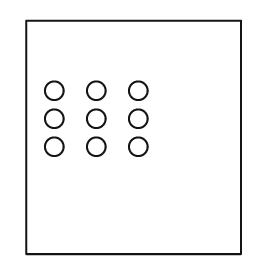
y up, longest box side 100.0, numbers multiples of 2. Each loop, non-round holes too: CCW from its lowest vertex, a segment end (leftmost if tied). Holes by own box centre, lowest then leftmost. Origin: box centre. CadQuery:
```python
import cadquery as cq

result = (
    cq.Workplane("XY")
    .moveTo(-46.0, -50.0)
    .lineTo(46.0, -50.0)
    .lineTo(46.0, 50.0)
    .lineTo(-46.0, 50.0)
    .close()
    .moveTo(-34.0, -4.0)
    .circle(4.0)
    .moveTo(-16.0, -4.0)
    .circle(4.0)
    .moveTo(2.0, -4.0)
    .circle(4.0)
    .moveTo(-34.0, 8.0)
    .circle(4.0)
    .moveTo(-16.0, 8.0)
    .circle(4.0)
    .moveTo(2.0, 8.0)
    .circle(4.0)
    .moveTo(-34.0, 20.0)
    .circle(4.0)
    .moveTo(-16.0, 20.0)
    .circle(4.0)
    .moveTo(2.0, 20.0)
    .circle(4.0)
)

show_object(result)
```